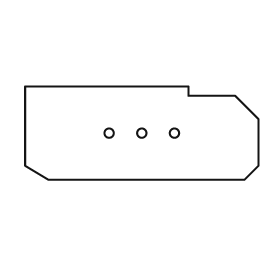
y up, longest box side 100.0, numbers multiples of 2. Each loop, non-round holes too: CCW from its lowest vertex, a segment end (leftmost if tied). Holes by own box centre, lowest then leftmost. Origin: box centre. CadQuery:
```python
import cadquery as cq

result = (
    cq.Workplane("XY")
    .moveTo(-40.0, -20.0)
    .lineTo(44.0, -20.0)
    .lineTo(50.0, -14.0)
    .lineTo(50.0, 6.0)
    .lineTo(40.0, 16.0)
    .lineTo(20.0, 16.0)
    .lineTo(20.0, 20.0)
    .lineTo(-50.0, 20.0)
    .lineTo(-50.0, -14.0)
    .close()
    .moveTo(-14.0, 0.0)
    .circle(2.0)
    .moveTo(0.0, 0.0)
    .circle(2.0)
    .moveTo(14.0, 0.0)
    .circle(2.0)
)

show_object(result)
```